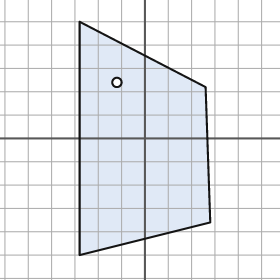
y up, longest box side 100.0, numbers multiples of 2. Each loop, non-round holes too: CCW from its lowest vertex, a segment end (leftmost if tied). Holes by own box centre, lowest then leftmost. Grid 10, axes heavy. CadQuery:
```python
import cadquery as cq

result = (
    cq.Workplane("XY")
    .moveTo(-28.0, -50.0)
    .lineTo(28.0, -36.0)
    .lineTo(26.0, 22.0)
    .lineTo(-28.0, 50.0)
    .close()
    .moveTo(-12.0, 24.0)
    .circle(2.0)
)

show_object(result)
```